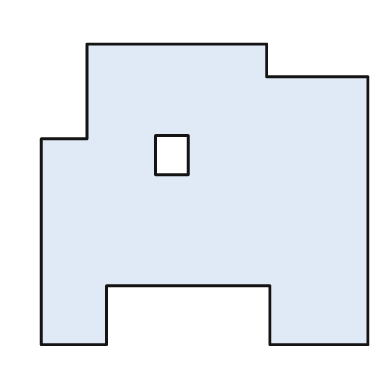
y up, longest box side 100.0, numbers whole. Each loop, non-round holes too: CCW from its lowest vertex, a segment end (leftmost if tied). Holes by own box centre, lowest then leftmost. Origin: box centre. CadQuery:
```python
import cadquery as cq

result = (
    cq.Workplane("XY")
    .moveTo(-50.0, -46.0)
    .lineTo(-30.0, -46.0)
    .lineTo(-30.0, -28.0)
    .lineTo(20.0, -28.0)
    .lineTo(20.0, -46.0)
    .lineTo(50.0, -46.0)
    .lineTo(50.0, 36.0)
    .lineTo(19.0, 36.0)
    .lineTo(19.0, 46.0)
    .lineTo(-36.0, 46.0)
    .lineTo(-36.0, 17.0)
    .lineTo(-50.0, 17.0)
    .close()
    .moveTo(-15.0, 6.0)
    .lineTo(-5.0, 6.0)
    .lineTo(-5.0, 18.0)
    .lineTo(-15.0, 18.0)
    .close()
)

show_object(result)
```